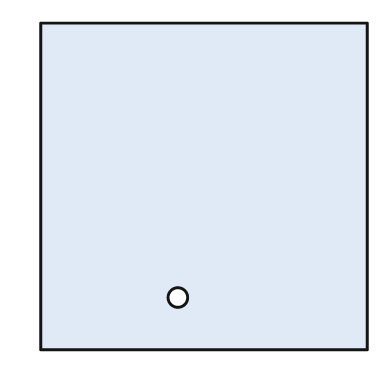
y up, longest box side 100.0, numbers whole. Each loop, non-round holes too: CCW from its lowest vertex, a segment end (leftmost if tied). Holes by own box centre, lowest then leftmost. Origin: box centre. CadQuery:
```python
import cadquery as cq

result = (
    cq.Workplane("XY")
    .moveTo(-50.0, -50.0)
    .lineTo(50.0, -50.0)
    .lineTo(50.0, 50.0)
    .lineTo(-50.0, 50.0)
    .close()
    .moveTo(-8.0, -34.0)
    .circle(3.0)
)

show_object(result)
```